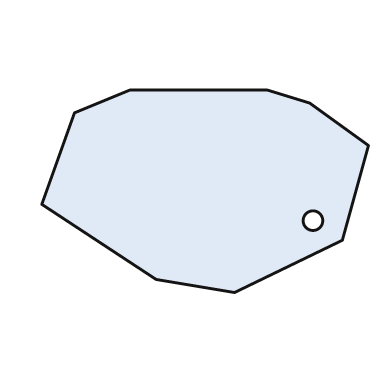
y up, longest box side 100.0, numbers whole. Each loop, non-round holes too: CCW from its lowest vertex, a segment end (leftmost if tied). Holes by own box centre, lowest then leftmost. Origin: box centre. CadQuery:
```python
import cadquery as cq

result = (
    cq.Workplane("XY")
    .moveTo(9.0, -31.0)
    .lineTo(42.0, -15.0)
    .lineTo(50.0, 14.0)
    .lineTo(32.0, 27.0)
    .lineTo(19.0, 31.0)
    .lineTo(-23.0, 31.0)
    .lineTo(-40.0, 24.0)
    .lineTo(-50.0, -4.0)
    .lineTo(-15.0, -27.0)
    .close()
    .moveTo(33.0, -9.0)
    .circle(3.0)
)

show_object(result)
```